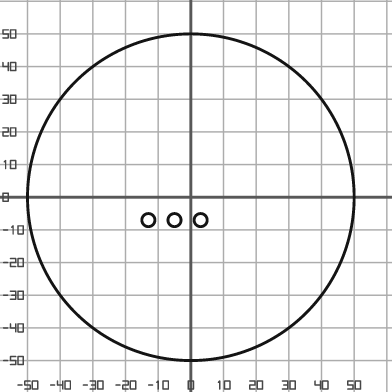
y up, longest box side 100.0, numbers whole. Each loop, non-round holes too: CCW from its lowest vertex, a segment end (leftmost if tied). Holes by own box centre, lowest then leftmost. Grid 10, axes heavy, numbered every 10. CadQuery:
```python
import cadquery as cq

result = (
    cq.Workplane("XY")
    .moveTo(0.0, 0.0)
    .circle(50.0)
    .moveTo(-13.0, -7.0)
    .circle(2.0)
    .moveTo(-5.0, -7.0)
    .circle(2.0)
    .moveTo(3.0, -7.0)
    .circle(2.0)
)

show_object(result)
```